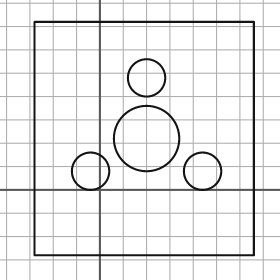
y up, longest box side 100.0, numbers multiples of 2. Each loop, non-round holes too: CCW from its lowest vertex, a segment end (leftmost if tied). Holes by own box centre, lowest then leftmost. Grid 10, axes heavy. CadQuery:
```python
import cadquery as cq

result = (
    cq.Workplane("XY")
    .moveTo(-28.0, -28.0)
    .lineTo(66.0, -28.0)
    .lineTo(66.0, 72.0)
    .lineTo(-28.0, 72.0)
    .close()
    .moveTo(-4.0, 8.0)
    .circle(8.0)
    .moveTo(44.0, 8.0)
    .circle(8.0)
    .moveTo(20.0, 22.0)
    .circle(14.0)
    .moveTo(20.0, 48.0)
    .circle(8.0)
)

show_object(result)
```